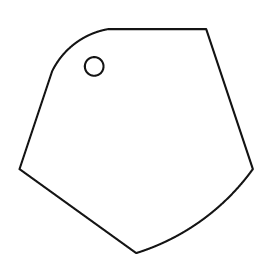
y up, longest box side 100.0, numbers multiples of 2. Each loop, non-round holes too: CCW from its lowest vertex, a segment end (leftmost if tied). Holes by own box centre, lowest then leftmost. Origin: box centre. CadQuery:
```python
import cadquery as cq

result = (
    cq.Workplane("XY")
    .moveTo(0.0, -48.0)
    .threePointArc((28.0, -34.0), (50.0, -12.0))
    .lineTo(30.0, 48.0)
    .lineTo(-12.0, 48.0)
    .threePointArc((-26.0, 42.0), (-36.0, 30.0))
    .lineTo(-50.0, -12.0)
    .close()
    .moveTo(-18.0, 32.0)
    .circle(4.0)
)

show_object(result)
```